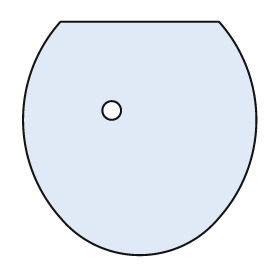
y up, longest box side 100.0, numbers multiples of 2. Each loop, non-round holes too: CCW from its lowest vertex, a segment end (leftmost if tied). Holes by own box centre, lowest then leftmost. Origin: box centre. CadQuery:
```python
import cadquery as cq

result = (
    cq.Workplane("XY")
    .moveTo(-34.0, -34.0)
    .threePointArc((0.0, -50.0), (34.0, -34.0))
    .threePointArc((50.0, 8.0), (34.0, 50.0))
    .lineTo(-34.0, 50.0)
    .threePointArc((-50.0, 8.0), (-34.0, -34.0))
    .close()
    .moveTo(-12.0, 12.0)
    .circle(4.0)
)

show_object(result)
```